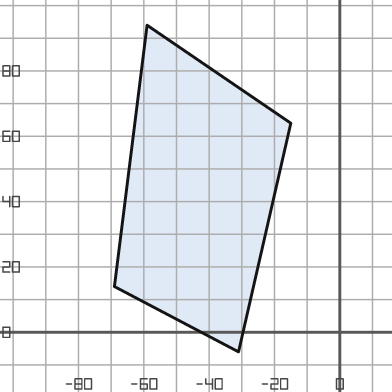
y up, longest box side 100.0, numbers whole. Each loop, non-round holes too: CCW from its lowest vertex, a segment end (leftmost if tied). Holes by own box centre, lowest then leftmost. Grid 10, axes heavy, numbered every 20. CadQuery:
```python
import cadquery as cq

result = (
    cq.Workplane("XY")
    .moveTo(-31.0, -6.0)
    .lineTo(-15.0, 64.0)
    .lineTo(-59.0, 94.0)
    .lineTo(-69.0, 14.0)
    .close()
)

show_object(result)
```